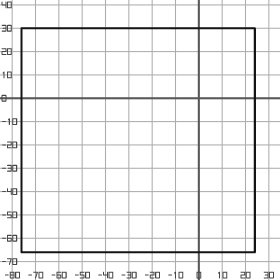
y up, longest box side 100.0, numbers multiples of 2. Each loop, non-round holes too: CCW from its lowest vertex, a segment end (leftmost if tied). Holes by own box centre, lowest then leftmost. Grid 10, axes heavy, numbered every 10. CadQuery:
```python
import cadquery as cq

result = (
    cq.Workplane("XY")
    .moveTo(-76.0, -66.0)
    .lineTo(24.0, -66.0)
    .lineTo(24.0, 30.0)
    .lineTo(-76.0, 30.0)
    .close()
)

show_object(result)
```